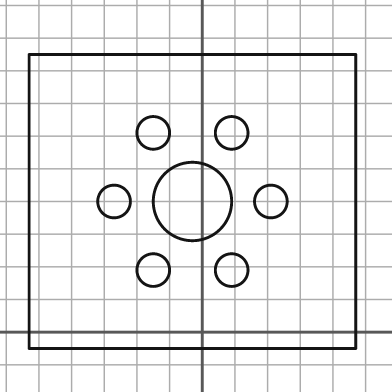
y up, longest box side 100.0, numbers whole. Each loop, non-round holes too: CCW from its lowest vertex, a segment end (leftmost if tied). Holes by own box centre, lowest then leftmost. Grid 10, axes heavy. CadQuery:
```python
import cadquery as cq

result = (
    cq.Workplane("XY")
    .moveTo(-53.0, -5.0)
    .lineTo(47.0, -5.0)
    .lineTo(47.0, 85.0)
    .lineTo(-53.0, 85.0)
    .close()
    .moveTo(-15.0, 19.0)
    .circle(5.0)
    .moveTo(9.0, 19.0)
    .circle(5.0)
    .moveTo(-27.0, 40.0)
    .circle(5.0)
    .moveTo(-3.0, 40.0)
    .circle(12.0)
    .moveTo(21.0, 40.0)
    .circle(5.0)
    .moveTo(-15.0, 61.0)
    .circle(5.0)
    .moveTo(9.0, 61.0)
    .circle(5.0)
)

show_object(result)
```